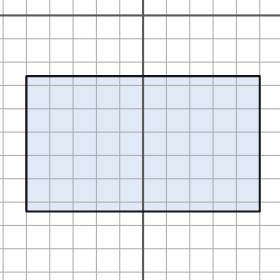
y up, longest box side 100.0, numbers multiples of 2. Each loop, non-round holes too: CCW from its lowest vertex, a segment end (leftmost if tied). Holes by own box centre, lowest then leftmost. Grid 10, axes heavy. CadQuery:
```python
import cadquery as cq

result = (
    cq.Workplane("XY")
    .moveTo(-50.0, -84.0)
    .lineTo(50.0, -84.0)
    .lineTo(50.0, -26.0)
    .lineTo(-50.0, -26.0)
    .close()
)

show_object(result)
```